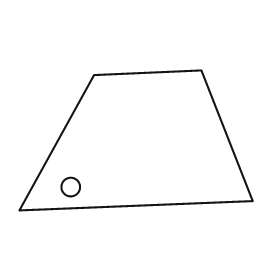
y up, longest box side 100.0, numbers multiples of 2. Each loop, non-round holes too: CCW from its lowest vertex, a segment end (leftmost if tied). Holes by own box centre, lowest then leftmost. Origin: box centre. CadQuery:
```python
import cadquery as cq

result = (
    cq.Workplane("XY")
    .moveTo(-50.0, -30.0)
    .lineTo(50.0, -26.0)
    .lineTo(28.0, 30.0)
    .lineTo(-18.0, 28.0)
    .close()
    .moveTo(-28.0, -20.0)
    .circle(4.0)
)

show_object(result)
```